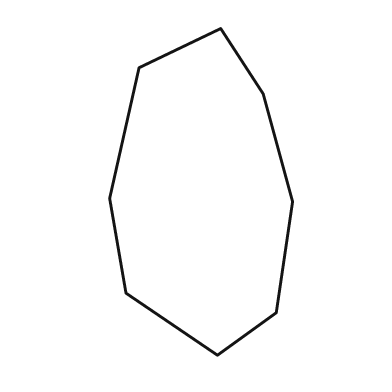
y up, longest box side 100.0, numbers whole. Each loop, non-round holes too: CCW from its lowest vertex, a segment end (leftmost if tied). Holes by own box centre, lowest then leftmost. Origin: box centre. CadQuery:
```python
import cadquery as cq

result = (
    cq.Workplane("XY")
    .moveTo(5.0, -50.0)
    .lineTo(23.0, -37.0)
    .lineTo(28.0, -3.0)
    .lineTo(19.0, 30.0)
    .lineTo(6.0, 50.0)
    .lineTo(-19.0, 38.0)
    .lineTo(-28.0, -2.0)
    .lineTo(-23.0, -31.0)
    .close()
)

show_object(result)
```